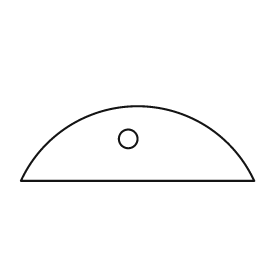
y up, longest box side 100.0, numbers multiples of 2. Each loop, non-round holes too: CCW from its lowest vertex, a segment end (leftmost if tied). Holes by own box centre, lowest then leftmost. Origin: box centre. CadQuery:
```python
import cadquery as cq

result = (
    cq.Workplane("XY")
    .moveTo(-50.0, -16.0)
    .lineTo(50.0, -16.0)
    .threePointArc((0.0, 16.0), (-50.0, -16.0))
    .close()
    .moveTo(-4.0, 2.0)
    .circle(4.0)
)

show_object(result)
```